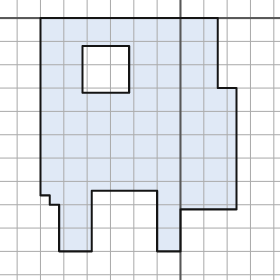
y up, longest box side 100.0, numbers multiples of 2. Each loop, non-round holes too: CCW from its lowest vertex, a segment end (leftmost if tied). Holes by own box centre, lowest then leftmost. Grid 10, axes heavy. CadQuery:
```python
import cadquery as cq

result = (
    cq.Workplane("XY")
    .moveTo(-52.0, -100.0)
    .lineTo(-38.0, -100.0)
    .lineTo(-38.0, -74.0)
    .lineTo(-10.0, -74.0)
    .lineTo(-10.0, -100.0)
    .lineTo(0.0, -100.0)
    .lineTo(0.0, -82.0)
    .lineTo(24.0, -82.0)
    .lineTo(24.0, -30.0)
    .lineTo(16.0, -30.0)
    .lineTo(16.0, 0.0)
    .lineTo(-60.0, 0.0)
    .lineTo(-60.0, -76.0)
    .lineTo(-56.0, -76.0)
    .lineTo(-56.0, -80.0)
    .lineTo(-52.0, -80.0)
    .close()
    .moveTo(-42.0, -32.0)
    .lineTo(-22.0, -32.0)
    .lineTo(-22.0, -12.0)
    .lineTo(-42.0, -12.0)
    .close()
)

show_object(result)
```